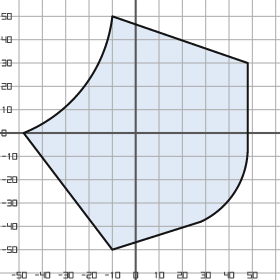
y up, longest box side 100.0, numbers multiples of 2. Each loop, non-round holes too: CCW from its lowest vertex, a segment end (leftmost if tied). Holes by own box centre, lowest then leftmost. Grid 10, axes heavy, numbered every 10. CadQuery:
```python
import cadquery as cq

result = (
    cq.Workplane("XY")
    .moveTo(-10.0, -50.0)
    .lineTo(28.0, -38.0)
    .threePointArc((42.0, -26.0), (48.0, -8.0))
    .lineTo(48.0, 30.0)
    .lineTo(-10.0, 50.0)
    .threePointArc((-22.0, 20.0), (-48.0, 0.0))
    .close()
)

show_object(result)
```